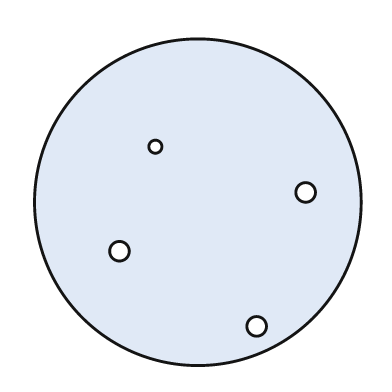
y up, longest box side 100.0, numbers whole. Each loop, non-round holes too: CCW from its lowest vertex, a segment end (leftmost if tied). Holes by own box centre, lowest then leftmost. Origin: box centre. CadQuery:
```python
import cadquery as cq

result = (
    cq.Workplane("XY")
    .moveTo(0.0, 0.0)
    .circle(50.0)
    .moveTo(18.0, -38.0)
    .circle(3.0)
    .moveTo(-24.0, -15.0)
    .circle(3.0)
    .moveTo(33.0, 3.0)
    .circle(3.0)
    .moveTo(-13.0, 17.0)
    .circle(2.0)
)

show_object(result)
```